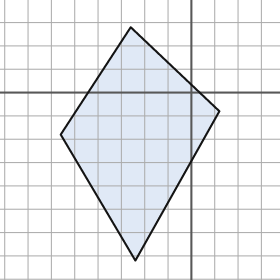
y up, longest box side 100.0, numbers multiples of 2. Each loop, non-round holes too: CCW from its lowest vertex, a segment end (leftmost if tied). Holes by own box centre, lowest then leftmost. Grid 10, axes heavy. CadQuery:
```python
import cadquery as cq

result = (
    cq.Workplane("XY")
    .moveTo(-24.0, -72.0)
    .lineTo(12.0, -8.0)
    .lineTo(-26.0, 28.0)
    .lineTo(-56.0, -18.0)
    .close()
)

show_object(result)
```